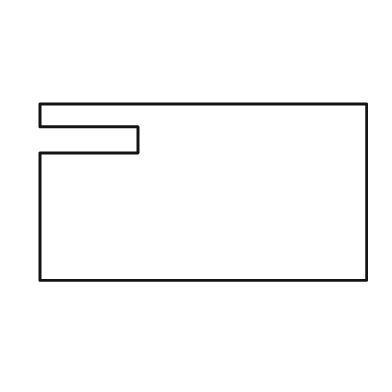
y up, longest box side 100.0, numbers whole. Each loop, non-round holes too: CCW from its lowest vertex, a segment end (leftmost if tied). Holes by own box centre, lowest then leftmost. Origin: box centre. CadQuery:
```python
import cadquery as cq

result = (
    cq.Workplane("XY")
    .moveTo(-50.0, -27.0)
    .lineTo(50.0, -27.0)
    .lineTo(50.0, 27.0)
    .lineTo(-50.0, 27.0)
    .lineTo(-50.0, 20.0)
    .lineTo(-20.0, 20.0)
    .lineTo(-20.0, 12.0)
    .lineTo(-50.0, 12.0)
    .close()
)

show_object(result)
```